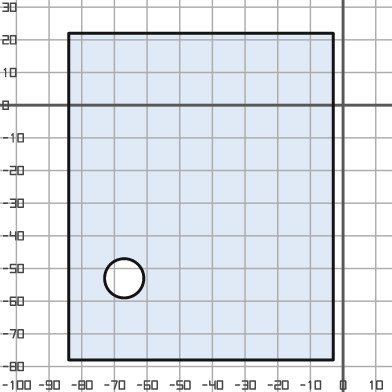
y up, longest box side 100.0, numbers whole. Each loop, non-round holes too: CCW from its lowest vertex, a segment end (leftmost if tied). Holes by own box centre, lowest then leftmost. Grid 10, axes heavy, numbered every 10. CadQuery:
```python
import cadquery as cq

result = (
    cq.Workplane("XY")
    .moveTo(-84.0, -78.0)
    .lineTo(-3.0, -78.0)
    .lineTo(-3.0, 22.0)
    .lineTo(-84.0, 22.0)
    .close()
    .moveTo(-67.0, -53.0)
    .circle(6.0)
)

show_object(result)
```